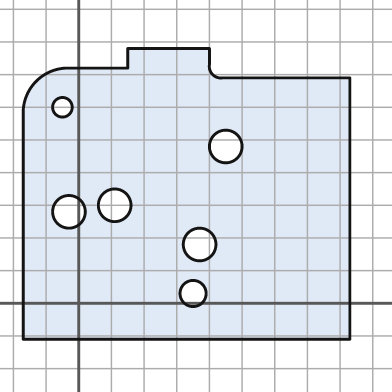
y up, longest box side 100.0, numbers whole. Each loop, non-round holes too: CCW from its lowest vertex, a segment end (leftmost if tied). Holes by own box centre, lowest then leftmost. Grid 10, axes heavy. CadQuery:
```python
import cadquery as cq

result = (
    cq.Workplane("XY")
    .moveTo(-17.0, -11.0)
    .lineTo(83.0, -11.0)
    .lineTo(83.0, 69.0)
    .lineTo(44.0, 69.0)
    .threePointArc((41.0, 70.0), (40.0, 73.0))
    .lineTo(40.0, 78.0)
    .lineTo(15.0, 78.0)
    .lineTo(15.0, 72.0)
    .lineTo(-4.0, 72.0)
    .threePointArc((-13.0, 68.0), (-17.0, 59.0))
    .close()
    .moveTo(35.0, 3.0)
    .circle(4.0)
    .moveTo(37.0, 18.0)
    .circle(5.0)
    .moveTo(-3.0, 28.0)
    .circle(5.0)
    .moveTo(11.0, 30.0)
    .circle(5.0)
    .moveTo(45.0, 48.0)
    .circle(5.0)
    .moveTo(-5.0, 60.0)
    .circle(3.0)
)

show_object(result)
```